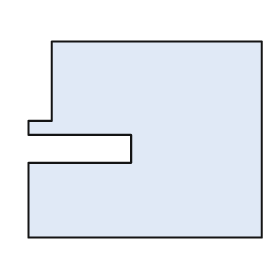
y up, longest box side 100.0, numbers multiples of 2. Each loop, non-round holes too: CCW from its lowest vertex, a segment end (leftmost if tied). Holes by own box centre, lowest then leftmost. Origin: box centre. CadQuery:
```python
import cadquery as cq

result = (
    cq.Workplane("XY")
    .moveTo(-50.0, -42.0)
    .lineTo(50.0, -42.0)
    .lineTo(50.0, 42.0)
    .lineTo(-40.0, 42.0)
    .lineTo(-40.0, 8.0)
    .lineTo(-50.0, 8.0)
    .lineTo(-50.0, 2.0)
    .lineTo(-6.0, 2.0)
    .lineTo(-6.0, -10.0)
    .lineTo(-50.0, -10.0)
    .close()
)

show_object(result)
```